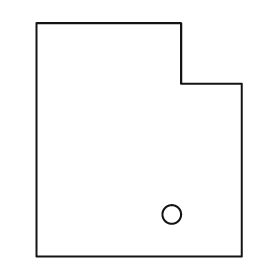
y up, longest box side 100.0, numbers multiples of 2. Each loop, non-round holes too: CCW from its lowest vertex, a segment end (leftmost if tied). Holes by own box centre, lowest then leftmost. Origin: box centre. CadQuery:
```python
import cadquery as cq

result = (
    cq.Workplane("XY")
    .moveTo(-44.0, -50.0)
    .lineTo(44.0, -50.0)
    .lineTo(44.0, 24.0)
    .lineTo(18.0, 24.0)
    .lineTo(18.0, 50.0)
    .lineTo(-44.0, 50.0)
    .close()
    .moveTo(14.0, -32.0)
    .circle(4.0)
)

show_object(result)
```